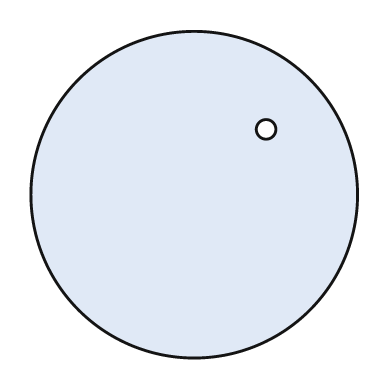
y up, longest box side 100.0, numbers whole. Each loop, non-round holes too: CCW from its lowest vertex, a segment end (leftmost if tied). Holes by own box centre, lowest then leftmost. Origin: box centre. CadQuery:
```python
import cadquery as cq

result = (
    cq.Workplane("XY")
    .moveTo(0.0, 0.0)
    .circle(50.0)
    .moveTo(22.0, 20.0)
    .circle(3.0)
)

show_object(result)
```